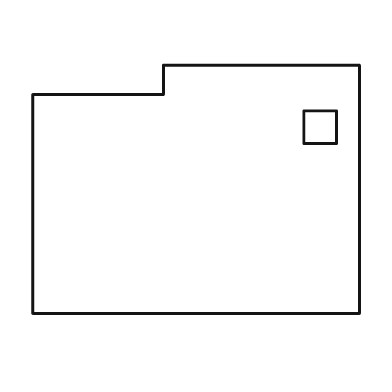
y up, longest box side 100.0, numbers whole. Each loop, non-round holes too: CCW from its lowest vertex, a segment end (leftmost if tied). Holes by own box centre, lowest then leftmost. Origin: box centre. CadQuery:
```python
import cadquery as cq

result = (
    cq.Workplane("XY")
    .moveTo(-50.0, -38.0)
    .lineTo(50.0, -38.0)
    .lineTo(50.0, 38.0)
    .lineTo(-10.0, 38.0)
    .lineTo(-10.0, 29.0)
    .lineTo(-50.0, 29.0)
    .close()
    .moveTo(33.0, 14.0)
    .lineTo(43.0, 14.0)
    .lineTo(43.0, 24.0)
    .lineTo(33.0, 24.0)
    .close()
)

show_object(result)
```